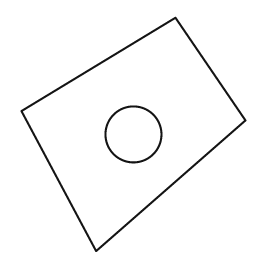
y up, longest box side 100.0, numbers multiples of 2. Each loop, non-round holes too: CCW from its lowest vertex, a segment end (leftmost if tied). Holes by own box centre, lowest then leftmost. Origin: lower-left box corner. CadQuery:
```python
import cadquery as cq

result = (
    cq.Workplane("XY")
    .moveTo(32.0, 0.0)
    .lineTo(96.0, 56.0)
    .lineTo(66.0, 100.0)
    .lineTo(0.0, 60.0)
    .close()
    .moveTo(48.0, 50.0)
    .circle(12.0)
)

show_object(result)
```